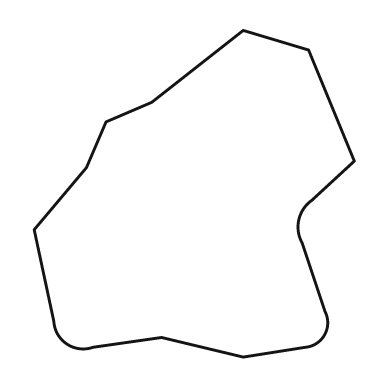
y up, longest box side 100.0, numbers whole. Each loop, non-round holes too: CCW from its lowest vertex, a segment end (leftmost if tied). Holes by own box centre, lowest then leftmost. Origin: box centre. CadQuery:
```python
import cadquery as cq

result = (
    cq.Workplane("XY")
    .moveTo(15.0, -50.0)
    .lineTo(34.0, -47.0)
    .threePointArc((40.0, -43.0), (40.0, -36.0))
    .lineTo(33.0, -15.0)
    .threePointArc((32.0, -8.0), (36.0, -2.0))
    .lineTo(49.0, 10.0)
    .lineTo(35.0, 44.0)
    .lineTo(15.0, 50.0)
    .lineTo(-13.0, 28.0)
    .lineTo(-27.0, 22.0)
    .lineTo(-33.0, 8.0)
    .lineTo(-49.0, -11.0)
    .lineTo(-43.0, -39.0)
    .threePointArc((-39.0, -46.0), (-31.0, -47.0))
    .lineTo(-10.0, -44.0)
    .close()
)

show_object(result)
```